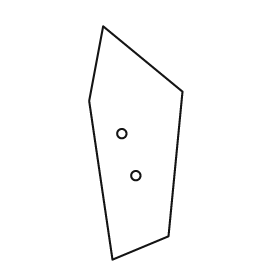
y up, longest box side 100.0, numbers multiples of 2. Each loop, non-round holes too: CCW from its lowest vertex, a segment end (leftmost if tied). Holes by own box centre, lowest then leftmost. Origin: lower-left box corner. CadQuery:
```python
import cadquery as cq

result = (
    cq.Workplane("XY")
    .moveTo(10.0, 0.0)
    .lineTo(34.0, 10.0)
    .lineTo(40.0, 72.0)
    .lineTo(6.0, 100.0)
    .lineTo(0.0, 68.0)
    .close()
    .moveTo(20.0, 36.0)
    .circle(2.0)
    .moveTo(14.0, 54.0)
    .circle(2.0)
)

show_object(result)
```